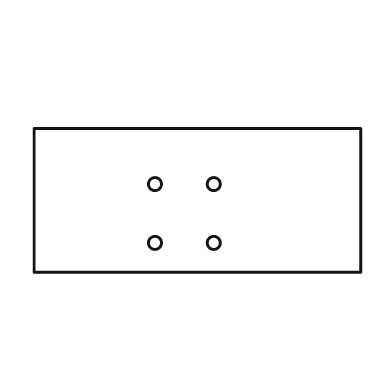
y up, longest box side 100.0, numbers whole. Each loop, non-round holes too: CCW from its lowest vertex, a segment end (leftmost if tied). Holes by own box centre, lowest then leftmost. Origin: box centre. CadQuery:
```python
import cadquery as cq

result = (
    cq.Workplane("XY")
    .moveTo(-50.0, -22.0)
    .lineTo(50.0, -22.0)
    .lineTo(50.0, 22.0)
    .lineTo(-50.0, 22.0)
    .close()
    .moveTo(-13.0, -13.0)
    .circle(2.0)
    .moveTo(5.0, -13.0)
    .circle(2.0)
    .moveTo(-13.0, 5.0)
    .circle(2.0)
    .moveTo(5.0, 5.0)
    .circle(2.0)
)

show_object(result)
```